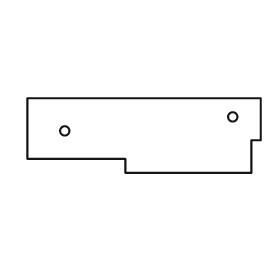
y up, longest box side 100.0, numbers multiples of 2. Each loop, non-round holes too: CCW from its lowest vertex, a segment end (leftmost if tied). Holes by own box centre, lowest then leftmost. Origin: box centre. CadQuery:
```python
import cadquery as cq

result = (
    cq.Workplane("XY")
    .moveTo(-8.0, -16.0)
    .lineTo(46.0, -16.0)
    .lineTo(46.0, -2.0)
    .lineTo(50.0, -2.0)
    .lineTo(50.0, 16.0)
    .lineTo(-50.0, 16.0)
    .lineTo(-50.0, -10.0)
    .lineTo(-8.0, -10.0)
    .close()
    .moveTo(-34.0, 2.0)
    .circle(2.0)
    .moveTo(38.0, 8.0)
    .circle(2.0)
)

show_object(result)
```